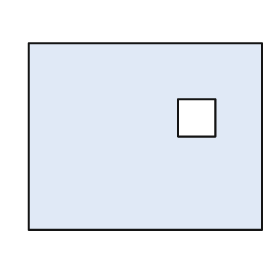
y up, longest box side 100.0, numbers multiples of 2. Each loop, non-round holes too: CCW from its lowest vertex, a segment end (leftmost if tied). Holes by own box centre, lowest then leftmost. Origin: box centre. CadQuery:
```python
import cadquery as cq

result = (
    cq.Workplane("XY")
    .moveTo(-50.0, -40.0)
    .lineTo(50.0, -40.0)
    .lineTo(50.0, 40.0)
    .lineTo(-50.0, 40.0)
    .close()
    .moveTo(14.0, 0.0)
    .lineTo(30.0, 0.0)
    .lineTo(30.0, 16.0)
    .lineTo(14.0, 16.0)
    .close()
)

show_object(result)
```